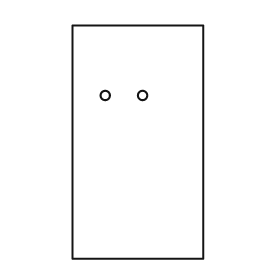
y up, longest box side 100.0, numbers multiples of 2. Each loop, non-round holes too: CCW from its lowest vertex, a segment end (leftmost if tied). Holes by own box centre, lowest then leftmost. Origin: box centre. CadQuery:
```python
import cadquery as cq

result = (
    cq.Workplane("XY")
    .moveTo(-28.0, -50.0)
    .lineTo(28.0, -50.0)
    .lineTo(28.0, 50.0)
    .lineTo(-28.0, 50.0)
    .close()
    .moveTo(-14.0, 20.0)
    .circle(2.0)
    .moveTo(2.0, 20.0)
    .circle(2.0)
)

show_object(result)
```